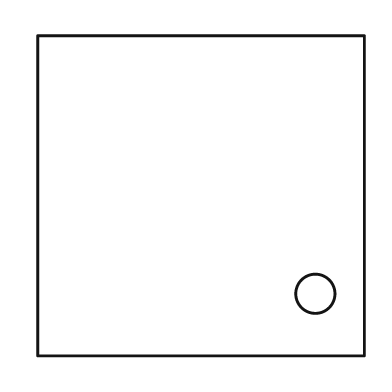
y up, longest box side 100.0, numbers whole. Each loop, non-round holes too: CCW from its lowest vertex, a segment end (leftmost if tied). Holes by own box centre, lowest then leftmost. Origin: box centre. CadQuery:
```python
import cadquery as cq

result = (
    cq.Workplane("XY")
    .moveTo(-50.0, -49.0)
    .lineTo(50.0, -49.0)
    .lineTo(50.0, 49.0)
    .lineTo(-50.0, 49.0)
    .close()
    .moveTo(35.0, -30.0)
    .circle(6.0)
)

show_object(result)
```